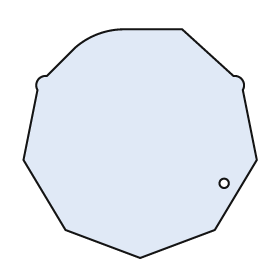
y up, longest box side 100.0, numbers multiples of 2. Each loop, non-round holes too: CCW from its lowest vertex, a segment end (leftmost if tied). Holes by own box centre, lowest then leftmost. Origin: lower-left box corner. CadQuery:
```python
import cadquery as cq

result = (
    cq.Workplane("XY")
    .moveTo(50.0, 0.0)
    .lineTo(82.0, 12.0)
    .lineTo(100.0, 42.0)
    .lineTo(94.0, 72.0)
    .threePointArc((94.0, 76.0), (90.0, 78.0))
    .lineTo(68.0, 98.0)
    .lineTo(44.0, 98.0)
    .threePointArc((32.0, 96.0), (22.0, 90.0))
    .lineTo(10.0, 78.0)
    .threePointArc((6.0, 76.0), (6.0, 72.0))
    .lineTo(0.0, 42.0)
    .lineTo(18.0, 12.0)
    .close()
    .moveTo(86.0, 32.0)
    .circle(2.0)
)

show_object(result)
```